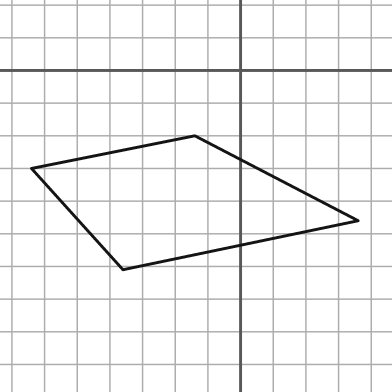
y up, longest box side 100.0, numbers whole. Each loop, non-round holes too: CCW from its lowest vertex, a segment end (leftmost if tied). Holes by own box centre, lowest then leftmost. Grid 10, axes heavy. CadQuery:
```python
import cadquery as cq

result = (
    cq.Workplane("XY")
    .moveTo(-36.0, -61.0)
    .lineTo(36.0, -46.0)
    .lineTo(-14.0, -20.0)
    .lineTo(-64.0, -30.0)
    .close()
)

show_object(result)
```